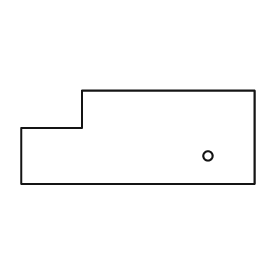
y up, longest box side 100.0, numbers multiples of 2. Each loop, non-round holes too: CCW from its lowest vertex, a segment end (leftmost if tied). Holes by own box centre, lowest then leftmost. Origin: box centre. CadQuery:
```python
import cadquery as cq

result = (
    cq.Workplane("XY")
    .moveTo(-50.0, -20.0)
    .lineTo(50.0, -20.0)
    .lineTo(50.0, 20.0)
    .lineTo(-24.0, 20.0)
    .lineTo(-24.0, 4.0)
    .lineTo(-50.0, 4.0)
    .close()
    .moveTo(30.0, -8.0)
    .circle(2.0)
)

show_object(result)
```